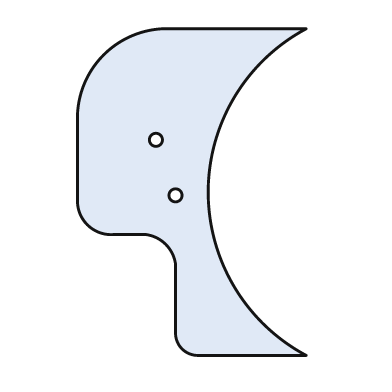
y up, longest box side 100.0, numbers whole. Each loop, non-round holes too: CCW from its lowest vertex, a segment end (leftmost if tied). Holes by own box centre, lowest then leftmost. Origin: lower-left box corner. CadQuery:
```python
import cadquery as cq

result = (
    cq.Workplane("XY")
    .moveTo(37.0, 0.0)
    .lineTo(70.0, 0.0)
    .threePointArc((40.0, 50.0), (70.0, 100.0))
    .lineTo(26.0, 100.0)
    .threePointArc((8.0, 92.0), (0.0, 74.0))
    .lineTo(0.0, 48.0)
    .threePointArc((3.0, 40.0), (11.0, 37.0))
    .lineTo(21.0, 37.0)
    .threePointArc((27.0, 34.0), (30.0, 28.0))
    .lineTo(30.0, 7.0)
    .threePointArc((32.0, 2.0), (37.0, 0.0))
    .close()
    .moveTo(30.0, 49.0)
    .circle(2.0)
    .moveTo(24.0, 66.0)
    .circle(2.0)
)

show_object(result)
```